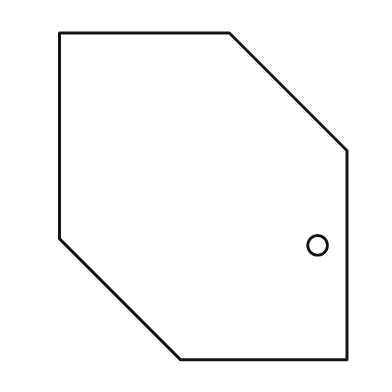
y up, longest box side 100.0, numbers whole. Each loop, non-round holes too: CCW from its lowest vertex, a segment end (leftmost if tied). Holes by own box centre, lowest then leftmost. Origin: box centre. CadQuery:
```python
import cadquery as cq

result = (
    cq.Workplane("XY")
    .moveTo(-7.0, -50.0)
    .lineTo(44.0, -50.0)
    .lineTo(44.0, 14.0)
    .lineTo(8.0, 50.0)
    .lineTo(-44.0, 50.0)
    .lineTo(-44.0, -13.0)
    .close()
    .moveTo(35.0, -15.0)
    .circle(3.0)
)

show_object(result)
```